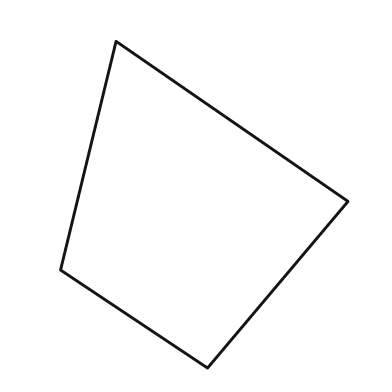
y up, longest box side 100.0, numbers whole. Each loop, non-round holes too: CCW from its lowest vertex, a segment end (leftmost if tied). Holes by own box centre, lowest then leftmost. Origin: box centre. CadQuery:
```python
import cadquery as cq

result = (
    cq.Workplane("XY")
    .moveTo(1.0, -50.0)
    .lineTo(44.0, 1.0)
    .lineTo(-27.0, 50.0)
    .lineTo(-44.0, -20.0)
    .close()
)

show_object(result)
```